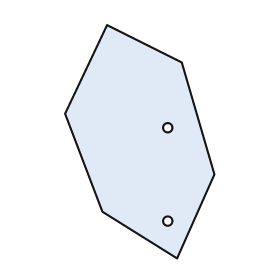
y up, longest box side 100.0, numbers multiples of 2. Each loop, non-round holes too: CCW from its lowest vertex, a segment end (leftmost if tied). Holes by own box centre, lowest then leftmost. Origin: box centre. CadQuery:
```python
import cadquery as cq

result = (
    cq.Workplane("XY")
    .moveTo(16.0, -50.0)
    .lineTo(32.0, -14.0)
    .lineTo(18.0, 34.0)
    .lineTo(-14.0, 50.0)
    .lineTo(-32.0, 12.0)
    .lineTo(-16.0, -30.0)
    .close()
    .moveTo(12.0, -34.0)
    .circle(2.0)
    .moveTo(12.0, 6.0)
    .circle(2.0)
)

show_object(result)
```